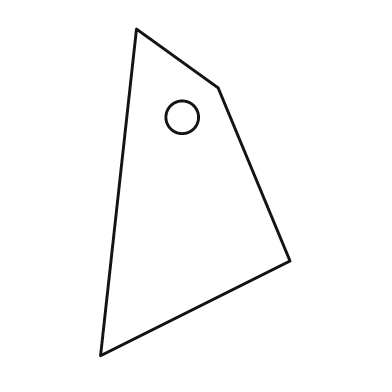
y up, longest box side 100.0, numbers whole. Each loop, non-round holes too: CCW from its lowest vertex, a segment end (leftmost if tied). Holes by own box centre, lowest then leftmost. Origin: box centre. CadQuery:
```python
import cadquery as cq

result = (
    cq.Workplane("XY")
    .moveTo(-29.0, -50.0)
    .lineTo(29.0, -21.0)
    .lineTo(7.0, 32.0)
    .lineTo(-18.0, 50.0)
    .close()
    .moveTo(-4.0, 23.0)
    .circle(5.0)
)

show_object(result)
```